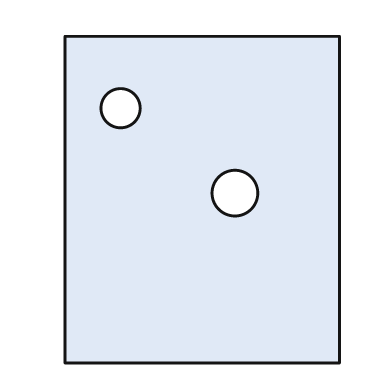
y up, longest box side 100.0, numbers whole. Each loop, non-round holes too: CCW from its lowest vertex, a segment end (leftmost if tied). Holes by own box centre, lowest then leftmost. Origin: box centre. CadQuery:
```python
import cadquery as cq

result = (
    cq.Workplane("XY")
    .moveTo(-42.0, -50.0)
    .lineTo(42.0, -50.0)
    .lineTo(42.0, 50.0)
    .lineTo(-42.0, 50.0)
    .close()
    .moveTo(10.0, 2.0)
    .circle(7.0)
    .moveTo(-25.0, 28.0)
    .circle(6.0)
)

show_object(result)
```